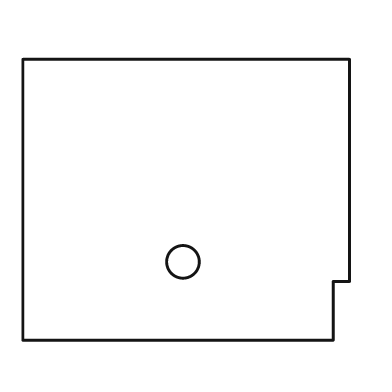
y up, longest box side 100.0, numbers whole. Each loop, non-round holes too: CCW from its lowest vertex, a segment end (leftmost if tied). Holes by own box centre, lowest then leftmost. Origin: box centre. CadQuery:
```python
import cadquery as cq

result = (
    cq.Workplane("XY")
    .moveTo(-50.0, -43.0)
    .lineTo(45.0, -43.0)
    .lineTo(45.0, -25.0)
    .lineTo(50.0, -25.0)
    .lineTo(50.0, 43.0)
    .lineTo(-50.0, 43.0)
    .close()
    .moveTo(-1.0, -19.0)
    .circle(5.0)
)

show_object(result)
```